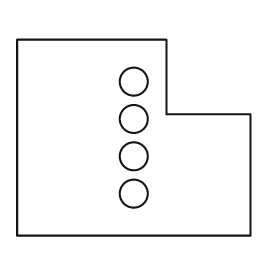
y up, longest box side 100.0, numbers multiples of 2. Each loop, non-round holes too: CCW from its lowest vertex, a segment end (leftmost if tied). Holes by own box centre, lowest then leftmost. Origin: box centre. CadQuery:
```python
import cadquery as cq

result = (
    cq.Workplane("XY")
    .moveTo(-50.0, -42.0)
    .lineTo(50.0, -42.0)
    .lineTo(50.0, 10.0)
    .lineTo(14.0, 10.0)
    .lineTo(14.0, 42.0)
    .lineTo(-50.0, 42.0)
    .close()
    .moveTo(0.0, -24.0)
    .circle(6.0)
    .moveTo(0.0, -8.0)
    .circle(6.0)
    .moveTo(0.0, 8.0)
    .circle(6.0)
    .moveTo(0.0, 24.0)
    .circle(6.0)
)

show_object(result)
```